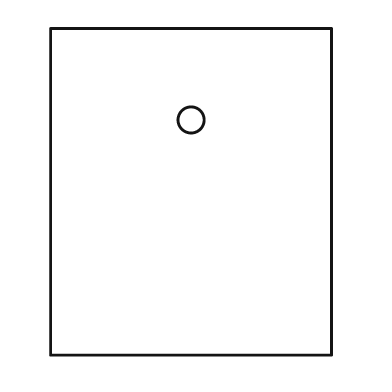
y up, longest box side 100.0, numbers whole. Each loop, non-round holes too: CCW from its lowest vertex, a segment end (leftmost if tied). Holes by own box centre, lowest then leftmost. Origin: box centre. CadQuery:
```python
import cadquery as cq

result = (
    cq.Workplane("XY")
    .moveTo(-43.0, -50.0)
    .lineTo(43.0, -50.0)
    .lineTo(43.0, 50.0)
    .lineTo(-43.0, 50.0)
    .close()
    .moveTo(0.0, 22.0)
    .circle(4.0)
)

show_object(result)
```